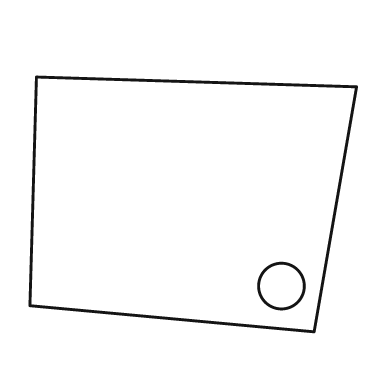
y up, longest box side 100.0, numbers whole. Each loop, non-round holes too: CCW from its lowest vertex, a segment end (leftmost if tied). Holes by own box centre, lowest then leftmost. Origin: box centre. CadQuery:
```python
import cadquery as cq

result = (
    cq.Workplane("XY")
    .moveTo(37.0, -39.0)
    .lineTo(50.0, 36.0)
    .lineTo(-48.0, 39.0)
    .lineTo(-50.0, -31.0)
    .close()
    .moveTo(27.0, -25.0)
    .circle(7.0)
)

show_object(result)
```